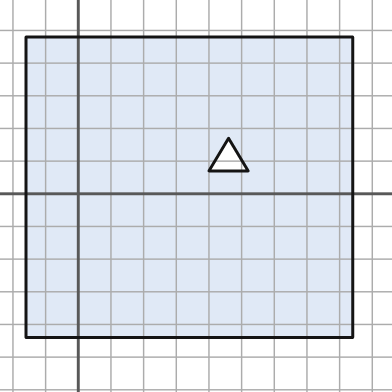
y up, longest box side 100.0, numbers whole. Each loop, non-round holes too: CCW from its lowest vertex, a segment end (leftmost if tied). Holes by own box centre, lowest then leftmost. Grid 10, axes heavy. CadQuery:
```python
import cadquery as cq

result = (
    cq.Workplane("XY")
    .moveTo(-16.0, -44.0)
    .lineTo(84.0, -44.0)
    .lineTo(84.0, 48.0)
    .lineTo(-16.0, 48.0)
    .close()
    .moveTo(40.0, 7.0)
    .lineTo(52.0, 7.0)
    .lineTo(46.0, 17.0)
    .close()
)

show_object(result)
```